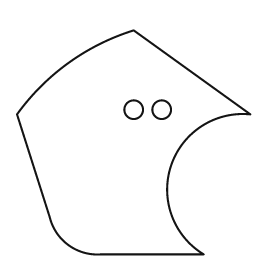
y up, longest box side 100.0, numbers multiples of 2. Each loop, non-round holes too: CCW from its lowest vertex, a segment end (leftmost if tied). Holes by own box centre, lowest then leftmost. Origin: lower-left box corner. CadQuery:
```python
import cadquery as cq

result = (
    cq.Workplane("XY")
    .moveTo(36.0, 0.0)
    .lineTo(80.0, 0.0)
    .threePointArc((66.0, 38.0), (100.0, 60.0))
    .lineTo(50.0, 96.0)
    .threePointArc((22.0, 82.0), (0.0, 60.0))
    .lineTo(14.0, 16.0)
    .threePointArc((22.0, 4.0), (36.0, 0.0))
    .close()
    .moveTo(50.0, 62.0)
    .circle(4.0)
    .moveTo(62.0, 62.0)
    .circle(4.0)
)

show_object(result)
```